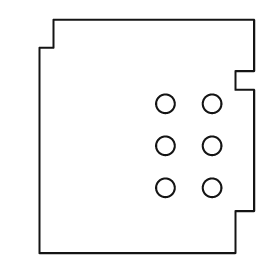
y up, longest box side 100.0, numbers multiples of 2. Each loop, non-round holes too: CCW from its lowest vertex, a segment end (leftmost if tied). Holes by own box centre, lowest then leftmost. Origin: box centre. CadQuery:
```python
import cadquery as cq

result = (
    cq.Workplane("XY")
    .moveTo(-46.0, -50.0)
    .lineTo(38.0, -50.0)
    .lineTo(38.0, -32.0)
    .lineTo(46.0, -32.0)
    .lineTo(46.0, 20.0)
    .lineTo(38.0, 20.0)
    .lineTo(38.0, 28.0)
    .lineTo(46.0, 28.0)
    .lineTo(46.0, 50.0)
    .lineTo(-40.0, 50.0)
    .lineTo(-40.0, 38.0)
    .lineTo(-46.0, 38.0)
    .close()
    .moveTo(8.0, -22.0)
    .circle(4.0)
    .moveTo(28.0, -22.0)
    .circle(4.0)
    .moveTo(8.0, -4.0)
    .circle(4.0)
    .moveTo(28.0, -4.0)
    .circle(4.0)
    .moveTo(8.0, 14.0)
    .circle(4.0)
    .moveTo(28.0, 14.0)
    .circle(4.0)
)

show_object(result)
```